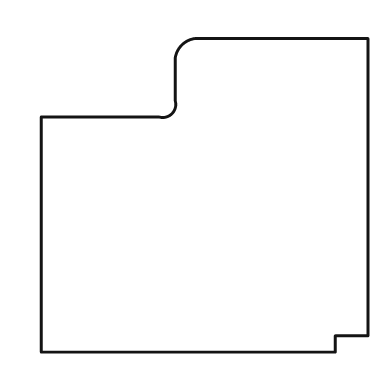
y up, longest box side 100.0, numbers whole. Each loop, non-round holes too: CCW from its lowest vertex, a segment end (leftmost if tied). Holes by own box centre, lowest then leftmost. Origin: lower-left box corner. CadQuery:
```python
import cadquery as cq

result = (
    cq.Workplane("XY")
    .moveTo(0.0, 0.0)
    .lineTo(90.0, 0.0)
    .lineTo(90.0, 5.0)
    .lineTo(100.0, 5.0)
    .lineTo(100.0, 96.0)
    .lineTo(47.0, 96.0)
    .threePointArc((43.0, 94.0), (41.0, 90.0))
    .lineTo(41.0, 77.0)
    .threePointArc((40.0, 73.0), (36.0, 72.0))
    .lineTo(0.0, 72.0)
    .close()
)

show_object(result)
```